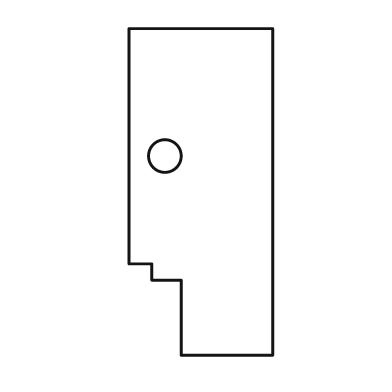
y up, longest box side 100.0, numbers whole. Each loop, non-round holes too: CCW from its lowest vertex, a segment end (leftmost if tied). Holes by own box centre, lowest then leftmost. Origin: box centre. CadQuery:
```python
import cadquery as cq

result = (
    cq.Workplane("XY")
    .moveTo(-6.0, -50.0)
    .lineTo(22.0, -50.0)
    .lineTo(22.0, 50.0)
    .lineTo(-22.0, 50.0)
    .lineTo(-22.0, -22.0)
    .lineTo(-15.0, -22.0)
    .lineTo(-15.0, -27.0)
    .lineTo(-6.0, -27.0)
    .close()
    .moveTo(-11.0, 11.0)
    .circle(5.0)
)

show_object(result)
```